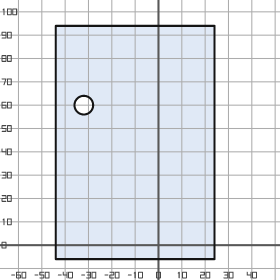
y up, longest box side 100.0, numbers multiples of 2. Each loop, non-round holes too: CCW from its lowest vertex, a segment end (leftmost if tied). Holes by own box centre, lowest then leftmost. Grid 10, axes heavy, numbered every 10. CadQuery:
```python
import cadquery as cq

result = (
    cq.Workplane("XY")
    .moveTo(-44.0, -6.0)
    .lineTo(24.0, -6.0)
    .lineTo(24.0, 94.0)
    .lineTo(-44.0, 94.0)
    .close()
    .moveTo(-32.0, 60.0)
    .circle(4.0)
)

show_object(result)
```